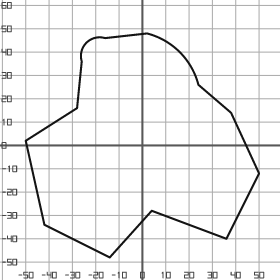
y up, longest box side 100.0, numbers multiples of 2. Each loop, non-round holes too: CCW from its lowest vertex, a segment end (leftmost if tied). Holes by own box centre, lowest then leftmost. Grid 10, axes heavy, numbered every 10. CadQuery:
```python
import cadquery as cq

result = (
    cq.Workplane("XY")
    .moveTo(-14.0, -48.0)
    .lineTo(4.0, -28.0)
    .lineTo(36.0, -40.0)
    .lineTo(50.0, -12.0)
    .lineTo(38.0, 14.0)
    .lineTo(24.0, 26.0)
    .threePointArc((16.0, 40.0), (2.0, 48.0))
    .lineTo(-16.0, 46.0)
    .threePointArc((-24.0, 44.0), (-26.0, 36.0))
    .lineTo(-28.0, 16.0)
    .lineTo(-50.0, 2.0)
    .lineTo(-42.0, -34.0)
    .close()
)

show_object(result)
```